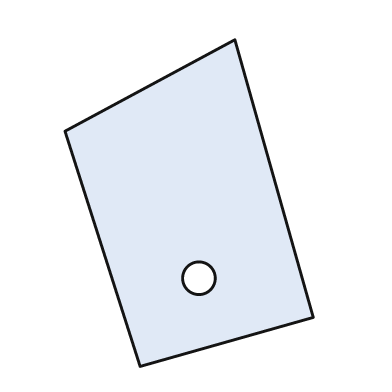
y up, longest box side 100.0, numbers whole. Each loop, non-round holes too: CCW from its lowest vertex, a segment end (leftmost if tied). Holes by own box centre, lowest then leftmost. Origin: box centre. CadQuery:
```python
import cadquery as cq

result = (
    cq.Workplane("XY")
    .moveTo(-15.0, -50.0)
    .lineTo(38.0, -35.0)
    .lineTo(14.0, 50.0)
    .lineTo(-38.0, 22.0)
    .close()
    .moveTo(3.0, -23.0)
    .circle(5.0)
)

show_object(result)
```